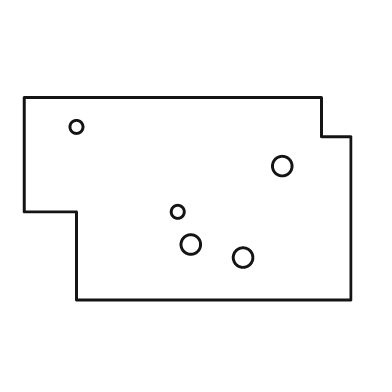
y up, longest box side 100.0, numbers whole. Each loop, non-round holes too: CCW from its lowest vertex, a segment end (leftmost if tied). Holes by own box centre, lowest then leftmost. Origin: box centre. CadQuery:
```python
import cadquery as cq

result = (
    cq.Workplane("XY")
    .moveTo(-34.0, -31.0)
    .lineTo(50.0, -31.0)
    .lineTo(50.0, 19.0)
    .lineTo(41.0, 19.0)
    .lineTo(41.0, 31.0)
    .lineTo(-50.0, 31.0)
    .lineTo(-50.0, -4.0)
    .lineTo(-34.0, -4.0)
    .close()
    .moveTo(17.0, -18.0)
    .circle(3.0)
    .moveTo(1.0, -14.0)
    .circle(3.0)
    .moveTo(-3.0, -4.0)
    .circle(2.0)
    .moveTo(29.0, 10.0)
    .circle(3.0)
    .moveTo(-34.0, 22.0)
    .circle(2.0)
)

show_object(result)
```